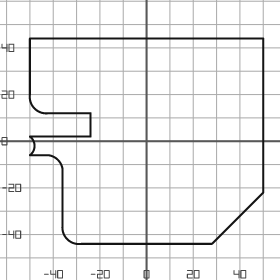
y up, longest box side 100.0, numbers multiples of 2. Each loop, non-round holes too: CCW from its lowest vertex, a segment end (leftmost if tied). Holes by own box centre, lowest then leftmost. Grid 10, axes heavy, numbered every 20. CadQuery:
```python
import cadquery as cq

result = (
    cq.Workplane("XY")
    .moveTo(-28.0, -44.0)
    .lineTo(28.0, -44.0)
    .lineTo(50.0, -22.0)
    .lineTo(50.0, 44.0)
    .lineTo(-50.0, 44.0)
    .lineTo(-50.0, 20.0)
    .threePointArc((-48.0, 14.0), (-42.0, 12.0))
    .lineTo(-24.0, 12.0)
    .lineTo(-24.0, 2.0)
    .lineTo(-50.0, 2.0)
    .threePointArc((-48.0, -2.0), (-50.0, -6.0))
    .lineTo(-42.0, -6.0)
    .threePointArc((-38.0, -8.0), (-36.0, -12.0))
    .lineTo(-36.0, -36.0)
    .threePointArc((-34.0, -42.0), (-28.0, -44.0))
    .close()
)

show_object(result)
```